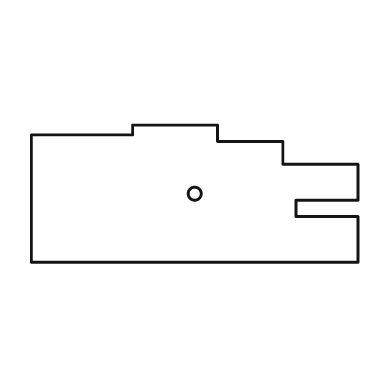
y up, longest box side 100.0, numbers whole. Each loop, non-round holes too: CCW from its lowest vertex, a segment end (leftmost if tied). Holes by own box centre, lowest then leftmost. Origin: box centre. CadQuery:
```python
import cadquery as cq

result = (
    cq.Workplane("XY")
    .moveTo(-50.0, -21.0)
    .lineTo(50.0, -21.0)
    .lineTo(50.0, -7.0)
    .lineTo(31.0, -7.0)
    .lineTo(31.0, -2.0)
    .lineTo(50.0, -2.0)
    .lineTo(50.0, 9.0)
    .lineTo(27.0, 9.0)
    .lineTo(27.0, 16.0)
    .lineTo(7.0, 16.0)
    .lineTo(7.0, 21.0)
    .lineTo(-19.0, 21.0)
    .lineTo(-19.0, 18.0)
    .lineTo(-50.0, 18.0)
    .close()
    .moveTo(0.0, 0.0)
    .circle(2.0)
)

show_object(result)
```